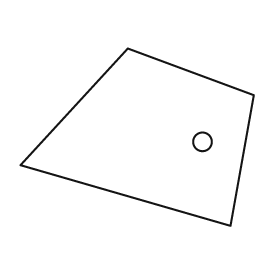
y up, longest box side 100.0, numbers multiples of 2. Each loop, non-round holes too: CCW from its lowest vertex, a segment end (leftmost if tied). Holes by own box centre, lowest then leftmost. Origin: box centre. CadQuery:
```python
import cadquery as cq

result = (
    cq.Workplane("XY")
    .moveTo(40.0, -38.0)
    .lineTo(50.0, 18.0)
    .lineTo(-4.0, 38.0)
    .lineTo(-50.0, -12.0)
    .close()
    .moveTo(28.0, -2.0)
    .circle(4.0)
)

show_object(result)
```